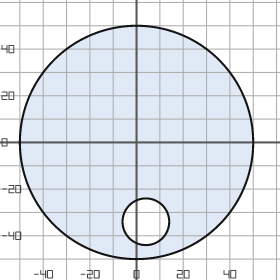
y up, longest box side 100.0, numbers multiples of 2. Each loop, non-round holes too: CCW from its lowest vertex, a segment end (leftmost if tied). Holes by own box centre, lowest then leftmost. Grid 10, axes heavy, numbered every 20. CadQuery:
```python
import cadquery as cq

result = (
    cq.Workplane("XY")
    .moveTo(0.0, 0.0)
    .circle(50.0)
    .moveTo(4.0, -34.0)
    .circle(10.0)
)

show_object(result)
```